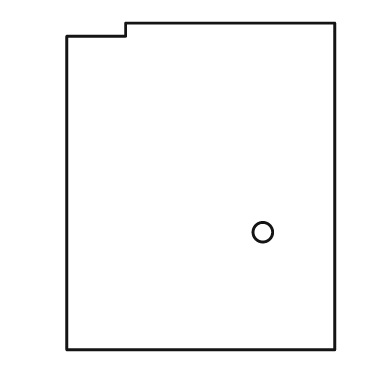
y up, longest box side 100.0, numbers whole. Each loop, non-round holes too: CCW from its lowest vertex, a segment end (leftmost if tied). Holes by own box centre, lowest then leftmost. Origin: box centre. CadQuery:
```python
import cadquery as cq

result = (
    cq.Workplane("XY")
    .moveTo(-41.0, -50.0)
    .lineTo(41.0, -50.0)
    .lineTo(41.0, 50.0)
    .lineTo(-23.0, 50.0)
    .lineTo(-23.0, 46.0)
    .lineTo(-41.0, 46.0)
    .close()
    .moveTo(19.0, -14.0)
    .circle(3.0)
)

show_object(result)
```